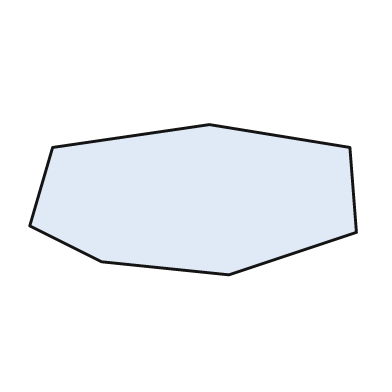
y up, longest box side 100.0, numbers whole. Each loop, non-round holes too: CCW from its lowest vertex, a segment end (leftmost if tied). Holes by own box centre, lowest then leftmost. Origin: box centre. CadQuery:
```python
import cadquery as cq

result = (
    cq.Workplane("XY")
    .moveTo(11.0, -23.0)
    .lineTo(50.0, -10.0)
    .lineTo(48.0, 16.0)
    .lineTo(5.0, 23.0)
    .lineTo(-43.0, 16.0)
    .lineTo(-50.0, -8.0)
    .lineTo(-28.0, -19.0)
    .close()
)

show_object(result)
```